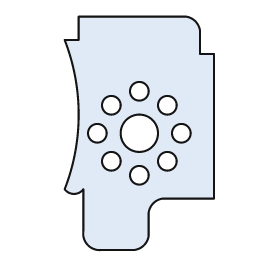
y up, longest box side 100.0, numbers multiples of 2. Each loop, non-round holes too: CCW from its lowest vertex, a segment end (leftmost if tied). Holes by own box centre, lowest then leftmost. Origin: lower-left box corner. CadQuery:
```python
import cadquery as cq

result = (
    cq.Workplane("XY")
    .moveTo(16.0, 0.0)
    .lineTo(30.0, 0.0)
    .threePointArc((34.0, 2.0), (36.0, 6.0))
    .lineTo(36.0, 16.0)
    .threePointArc((38.0, 20.0), (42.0, 22.0))
    .lineTo(64.0, 22.0)
    .lineTo(64.0, 84.0)
    .lineTo(58.0, 84.0)
    .lineTo(58.0, 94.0)
    .threePointArc((56.0, 98.0), (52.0, 100.0))
    .lineTo(6.0, 100.0)
    .lineTo(6.0, 90.0)
    .lineTo(0.0, 90.0)
    .threePointArc((6.0, 58.0), (0.0, 26.0))
    .threePointArc((4.0, 24.0), (8.0, 26.0))
    .lineTo(8.0, 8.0)
    .threePointArc((10.0, 2.0), (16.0, 0.0))
    .close()
    .moveTo(32.0, 32.0)
    .circle(4.0)
    .moveTo(20.0, 38.0)
    .circle(4.0)
    .moveTo(44.0, 38.0)
    .circle(4.0)
    .moveTo(14.0, 50.0)
    .circle(4.0)
    .moveTo(32.0, 50.0)
    .circle(8.0)
    .moveTo(50.0, 50.0)
    .circle(4.0)
    .moveTo(20.0, 62.0)
    .circle(4.0)
    .moveTo(44.0, 62.0)
    .circle(4.0)
    .moveTo(32.0, 68.0)
    .circle(4.0)
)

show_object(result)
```